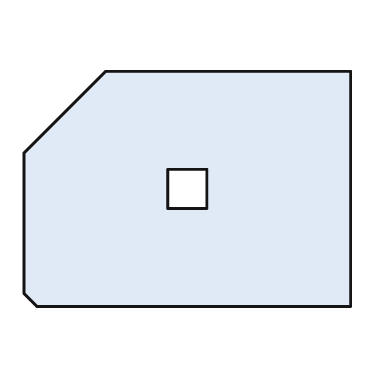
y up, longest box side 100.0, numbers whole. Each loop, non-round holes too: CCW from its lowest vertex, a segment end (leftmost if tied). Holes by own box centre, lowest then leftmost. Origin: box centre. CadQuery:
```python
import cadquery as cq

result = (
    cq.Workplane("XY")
    .moveTo(-46.0, -36.0)
    .lineTo(50.0, -36.0)
    .lineTo(50.0, 36.0)
    .lineTo(-25.0, 36.0)
    .lineTo(-50.0, 11.0)
    .lineTo(-50.0, -32.0)
    .close()
    .moveTo(-6.0, -6.0)
    .lineTo(6.0, -6.0)
    .lineTo(6.0, 6.0)
    .lineTo(-6.0, 6.0)
    .close()
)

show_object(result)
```